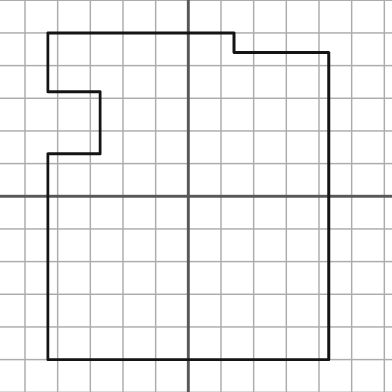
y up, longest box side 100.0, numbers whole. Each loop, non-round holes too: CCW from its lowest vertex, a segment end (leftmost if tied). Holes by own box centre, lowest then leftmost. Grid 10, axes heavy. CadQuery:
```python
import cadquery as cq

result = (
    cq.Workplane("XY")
    .moveTo(-43.0, -50.0)
    .lineTo(43.0, -50.0)
    .lineTo(43.0, 44.0)
    .lineTo(14.0, 44.0)
    .lineTo(14.0, 50.0)
    .lineTo(-43.0, 50.0)
    .lineTo(-43.0, 32.0)
    .lineTo(-27.0, 32.0)
    .lineTo(-27.0, 13.0)
    .lineTo(-43.0, 13.0)
    .close()
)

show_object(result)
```